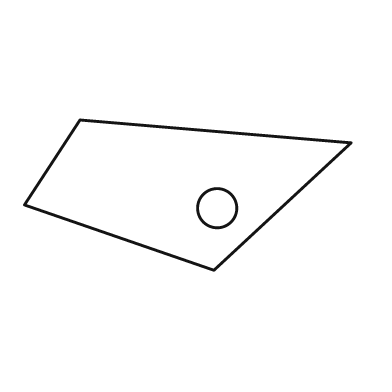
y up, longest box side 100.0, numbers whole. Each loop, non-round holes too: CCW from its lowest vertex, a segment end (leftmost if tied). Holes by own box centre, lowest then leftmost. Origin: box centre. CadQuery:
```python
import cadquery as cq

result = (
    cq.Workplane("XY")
    .moveTo(8.0, -23.0)
    .lineTo(50.0, 16.0)
    .lineTo(-33.0, 23.0)
    .lineTo(-50.0, -3.0)
    .close()
    .moveTo(9.0, -4.0)
    .circle(6.0)
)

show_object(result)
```